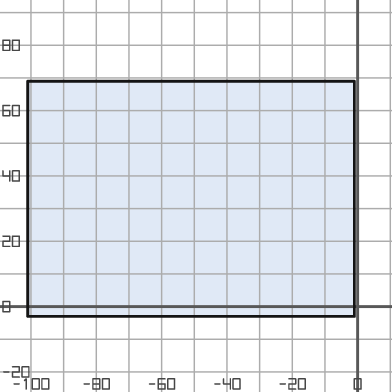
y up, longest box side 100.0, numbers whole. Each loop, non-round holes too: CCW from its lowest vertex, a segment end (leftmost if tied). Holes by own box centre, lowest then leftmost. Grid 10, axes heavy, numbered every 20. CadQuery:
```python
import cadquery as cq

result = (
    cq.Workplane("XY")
    .moveTo(-101.0, -3.0)
    .lineTo(-1.0, -3.0)
    .lineTo(-1.0, 69.0)
    .lineTo(-101.0, 69.0)
    .close()
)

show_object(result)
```